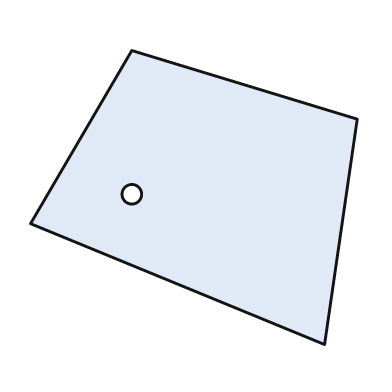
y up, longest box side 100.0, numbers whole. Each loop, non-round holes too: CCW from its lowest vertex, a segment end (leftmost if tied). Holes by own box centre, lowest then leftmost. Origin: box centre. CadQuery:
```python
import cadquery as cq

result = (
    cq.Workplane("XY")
    .moveTo(40.0, -45.0)
    .lineTo(50.0, 24.0)
    .lineTo(-19.0, 45.0)
    .lineTo(-50.0, -8.0)
    .close()
    .moveTo(-19.0, 1.0)
    .circle(3.0)
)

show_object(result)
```